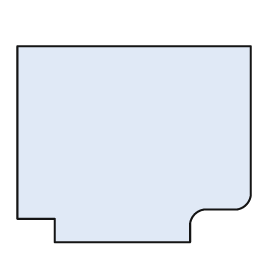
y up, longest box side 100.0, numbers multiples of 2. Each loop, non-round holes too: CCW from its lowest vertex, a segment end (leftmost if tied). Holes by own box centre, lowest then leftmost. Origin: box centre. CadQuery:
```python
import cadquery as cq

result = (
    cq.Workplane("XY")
    .moveTo(-34.0, -42.0)
    .lineTo(24.0, -42.0)
    .lineTo(24.0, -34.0)
    .threePointArc((26.0, -30.0), (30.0, -28.0))
    .lineTo(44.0, -28.0)
    .threePointArc((48.0, -26.0), (50.0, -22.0))
    .lineTo(50.0, 42.0)
    .lineTo(-50.0, 42.0)
    .lineTo(-50.0, -32.0)
    .lineTo(-34.0, -32.0)
    .close()
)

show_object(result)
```